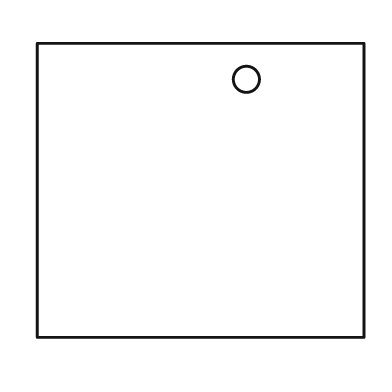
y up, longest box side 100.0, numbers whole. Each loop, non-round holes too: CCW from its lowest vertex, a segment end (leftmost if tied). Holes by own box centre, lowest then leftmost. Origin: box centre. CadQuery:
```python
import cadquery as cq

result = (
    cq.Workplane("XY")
    .moveTo(-50.0, -45.0)
    .lineTo(50.0, -45.0)
    .lineTo(50.0, 45.0)
    .lineTo(-50.0, 45.0)
    .close()
    .moveTo(14.0, 34.0)
    .circle(4.0)
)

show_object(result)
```